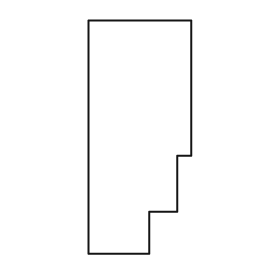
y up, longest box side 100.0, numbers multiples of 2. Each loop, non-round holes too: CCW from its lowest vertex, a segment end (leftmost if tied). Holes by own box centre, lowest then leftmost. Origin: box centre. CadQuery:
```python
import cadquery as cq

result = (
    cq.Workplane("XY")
    .moveTo(-22.0, -50.0)
    .lineTo(4.0, -50.0)
    .lineTo(4.0, -32.0)
    .lineTo(16.0, -32.0)
    .lineTo(16.0, -8.0)
    .lineTo(22.0, -8.0)
    .lineTo(22.0, 50.0)
    .lineTo(-22.0, 50.0)
    .close()
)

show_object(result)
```